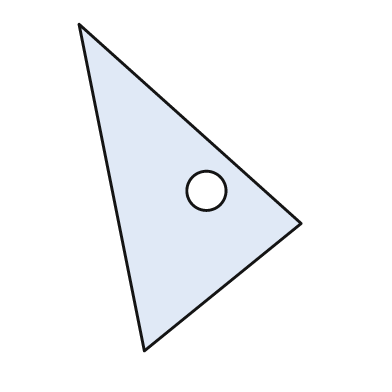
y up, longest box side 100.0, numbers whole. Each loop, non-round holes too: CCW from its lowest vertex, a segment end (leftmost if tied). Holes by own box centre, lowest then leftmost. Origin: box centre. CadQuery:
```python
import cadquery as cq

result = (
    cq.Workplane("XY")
    .moveTo(-14.0, -50.0)
    .lineTo(34.0, -11.0)
    .lineTo(-34.0, 50.0)
    .close()
    .moveTo(5.0, -1.0)
    .circle(6.0)
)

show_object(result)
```